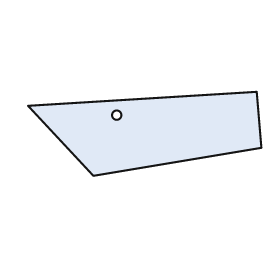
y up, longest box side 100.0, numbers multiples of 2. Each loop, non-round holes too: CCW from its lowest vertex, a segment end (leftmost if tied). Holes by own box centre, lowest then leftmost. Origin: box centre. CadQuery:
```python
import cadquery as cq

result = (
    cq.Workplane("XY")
    .moveTo(-22.0, -18.0)
    .lineTo(50.0, -6.0)
    .lineTo(48.0, 18.0)
    .lineTo(-50.0, 12.0)
    .close()
    .moveTo(-12.0, 8.0)
    .circle(2.0)
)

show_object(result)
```